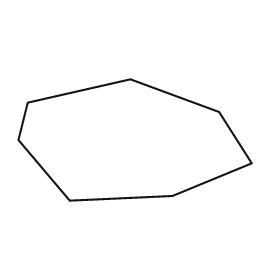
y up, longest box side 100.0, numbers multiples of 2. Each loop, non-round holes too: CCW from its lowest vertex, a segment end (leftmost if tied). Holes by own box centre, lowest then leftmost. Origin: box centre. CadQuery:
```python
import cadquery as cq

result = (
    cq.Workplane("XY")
    .moveTo(-28.0, -26.0)
    .lineTo(16.0, -24.0)
    .lineTo(50.0, -10.0)
    .lineTo(36.0, 12.0)
    .lineTo(-2.0, 26.0)
    .lineTo(-46.0, 16.0)
    .lineTo(-50.0, 0.0)
    .close()
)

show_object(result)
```